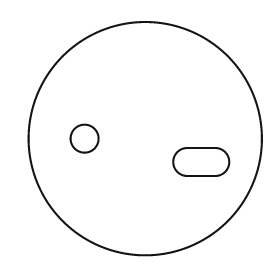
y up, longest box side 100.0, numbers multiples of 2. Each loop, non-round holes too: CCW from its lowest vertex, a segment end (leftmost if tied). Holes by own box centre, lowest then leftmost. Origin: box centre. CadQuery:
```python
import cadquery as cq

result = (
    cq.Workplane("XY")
    .moveTo(0.0, 0.0)
    .circle(50.0)
    .moveTo(18.0, -16.0)
    .lineTo(30.0, -16.0)
    .threePointArc((36.0, -10.0), (30.0, -4.0))
    .lineTo(18.0, -4.0)
    .threePointArc((12.0, -10.0), (18.0, -16.0))
    .close()
    .moveTo(-26.0, 0.0)
    .circle(6.0)
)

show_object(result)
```